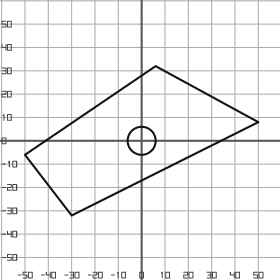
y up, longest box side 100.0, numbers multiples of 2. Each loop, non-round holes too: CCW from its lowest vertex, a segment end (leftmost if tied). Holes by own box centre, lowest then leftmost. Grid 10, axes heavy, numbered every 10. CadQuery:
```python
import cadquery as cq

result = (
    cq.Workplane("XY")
    .moveTo(-30.0, -32.0)
    .lineTo(50.0, 8.0)
    .lineTo(6.0, 32.0)
    .lineTo(-50.0, -6.0)
    .close()
    .moveTo(0.0, 0.0)
    .circle(6.0)
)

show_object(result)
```